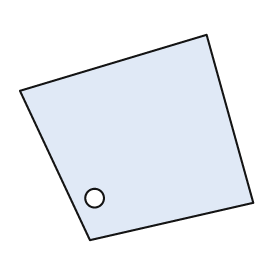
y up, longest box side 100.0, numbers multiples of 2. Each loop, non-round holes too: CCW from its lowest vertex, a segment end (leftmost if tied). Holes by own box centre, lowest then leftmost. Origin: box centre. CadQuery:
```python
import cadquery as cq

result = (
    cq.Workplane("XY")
    .moveTo(-20.0, -44.0)
    .lineTo(50.0, -28.0)
    .lineTo(30.0, 44.0)
    .lineTo(-50.0, 20.0)
    .close()
    .moveTo(-18.0, -26.0)
    .circle(4.0)
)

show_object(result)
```